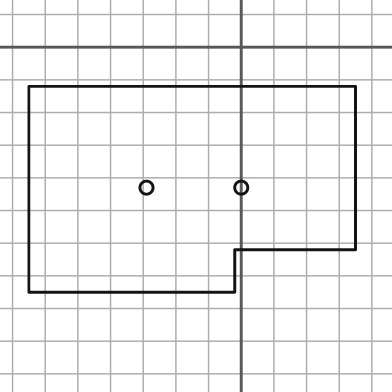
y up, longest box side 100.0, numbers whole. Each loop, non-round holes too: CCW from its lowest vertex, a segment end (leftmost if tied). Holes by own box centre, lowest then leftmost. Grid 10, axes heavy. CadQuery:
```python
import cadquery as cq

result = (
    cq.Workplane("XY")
    .moveTo(-65.0, -75.0)
    .lineTo(-2.0, -75.0)
    .lineTo(-2.0, -62.0)
    .lineTo(35.0, -62.0)
    .lineTo(35.0, -12.0)
    .lineTo(-65.0, -12.0)
    .close()
    .moveTo(-29.0, -43.0)
    .circle(2.0)
    .moveTo(0.0, -43.0)
    .circle(2.0)
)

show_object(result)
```